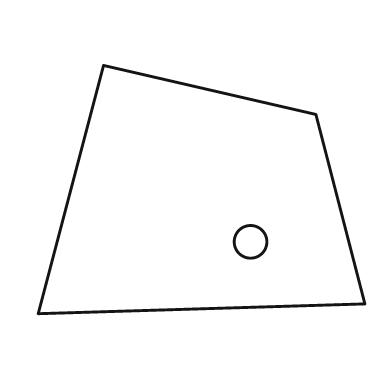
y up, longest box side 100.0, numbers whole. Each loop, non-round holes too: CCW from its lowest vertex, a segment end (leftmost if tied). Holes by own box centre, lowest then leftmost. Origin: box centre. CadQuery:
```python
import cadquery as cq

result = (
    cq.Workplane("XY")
    .moveTo(-50.0, -38.0)
    .lineTo(50.0, -35.0)
    .lineTo(35.0, 23.0)
    .lineTo(-30.0, 38.0)
    .close()
    .moveTo(15.0, -16.0)
    .circle(5.0)
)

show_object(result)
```